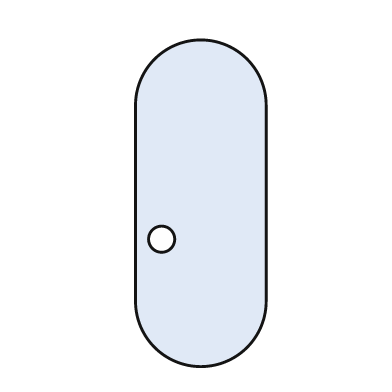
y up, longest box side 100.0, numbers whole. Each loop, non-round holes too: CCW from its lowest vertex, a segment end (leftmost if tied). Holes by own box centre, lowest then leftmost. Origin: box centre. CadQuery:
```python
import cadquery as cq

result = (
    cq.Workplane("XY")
    .moveTo(-20.0, -30.0)
    .threePointArc((0.0, -50.0), (20.0, -30.0))
    .lineTo(20.0, 30.0)
    .threePointArc((0.0, 50.0), (-20.0, 30.0))
    .close()
    .moveTo(-12.0, -11.0)
    .circle(4.0)
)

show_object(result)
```